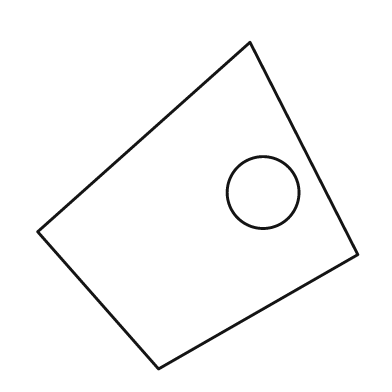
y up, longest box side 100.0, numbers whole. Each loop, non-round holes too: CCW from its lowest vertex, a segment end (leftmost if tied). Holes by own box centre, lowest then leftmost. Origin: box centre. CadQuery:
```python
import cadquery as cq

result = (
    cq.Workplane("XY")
    .moveTo(-12.0, -50.0)
    .lineTo(49.0, -15.0)
    .lineTo(16.0, 50.0)
    .lineTo(-49.0, -8.0)
    .close()
    .moveTo(20.0, 4.0)
    .circle(11.0)
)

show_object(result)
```